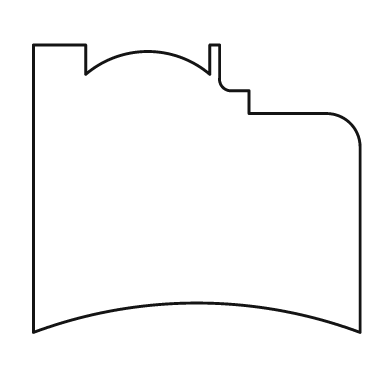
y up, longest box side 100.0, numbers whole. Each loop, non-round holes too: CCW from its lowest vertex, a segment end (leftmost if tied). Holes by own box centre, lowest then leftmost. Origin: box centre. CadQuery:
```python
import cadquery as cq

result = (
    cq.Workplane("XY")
    .moveTo(-50.0, -44.0)
    .threePointArc((0.0, -35.0), (50.0, -44.0))
    .lineTo(50.0, 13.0)
    .threePointArc((47.0, 20.0), (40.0, 23.0))
    .lineTo(16.0, 23.0)
    .lineTo(16.0, 30.0)
    .lineTo(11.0, 30.0)
    .threePointArc((8.0, 31.0), (7.0, 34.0))
    .lineTo(7.0, 44.0)
    .lineTo(4.0, 44.0)
    .lineTo(4.0, 35.0)
    .threePointArc((-15.0, 42.0), (-34.0, 35.0))
    .lineTo(-34.0, 44.0)
    .lineTo(-50.0, 44.0)
    .close()
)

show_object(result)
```